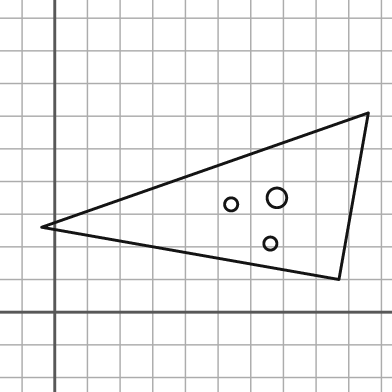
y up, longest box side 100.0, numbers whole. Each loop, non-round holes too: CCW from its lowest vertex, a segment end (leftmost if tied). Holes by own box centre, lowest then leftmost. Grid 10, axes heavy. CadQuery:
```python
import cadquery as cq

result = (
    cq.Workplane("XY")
    .moveTo(87.0, 10.0)
    .lineTo(96.0, 61.0)
    .lineTo(-4.0, 26.0)
    .close()
    .moveTo(66.0, 21.0)
    .circle(2.0)
    .moveTo(54.0, 33.0)
    .circle(2.0)
    .moveTo(68.0, 35.0)
    .circle(3.0)
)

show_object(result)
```